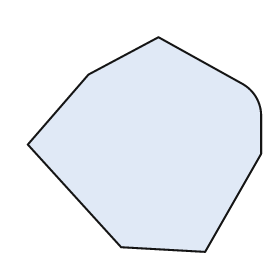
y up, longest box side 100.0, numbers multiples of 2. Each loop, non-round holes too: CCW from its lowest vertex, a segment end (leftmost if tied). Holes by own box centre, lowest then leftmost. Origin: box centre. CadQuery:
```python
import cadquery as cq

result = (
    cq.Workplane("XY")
    .moveTo(26.0, -46.0)
    .lineTo(50.0, -4.0)
    .lineTo(50.0, 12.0)
    .threePointArc((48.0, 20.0), (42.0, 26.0))
    .lineTo(6.0, 46.0)
    .lineTo(-24.0, 30.0)
    .lineTo(-50.0, 0.0)
    .lineTo(-10.0, -44.0)
    .close()
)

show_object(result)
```